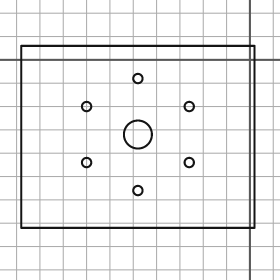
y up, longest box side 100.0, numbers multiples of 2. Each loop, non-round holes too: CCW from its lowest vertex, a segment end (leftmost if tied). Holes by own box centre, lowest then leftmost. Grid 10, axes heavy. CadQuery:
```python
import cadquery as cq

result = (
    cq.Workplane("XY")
    .moveTo(-98.0, -72.0)
    .lineTo(2.0, -72.0)
    .lineTo(2.0, 6.0)
    .lineTo(-98.0, 6.0)
    .close()
    .moveTo(-48.0, -56.0)
    .circle(2.0)
    .moveTo(-70.0, -44.0)
    .circle(2.0)
    .moveTo(-26.0, -44.0)
    .circle(2.0)
    .moveTo(-48.0, -32.0)
    .circle(6.0)
    .moveTo(-70.0, -20.0)
    .circle(2.0)
    .moveTo(-26.0, -20.0)
    .circle(2.0)
    .moveTo(-48.0, -8.0)
    .circle(2.0)
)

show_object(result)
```